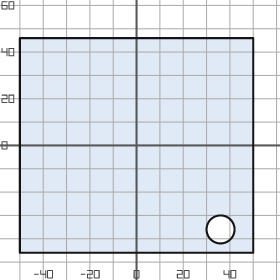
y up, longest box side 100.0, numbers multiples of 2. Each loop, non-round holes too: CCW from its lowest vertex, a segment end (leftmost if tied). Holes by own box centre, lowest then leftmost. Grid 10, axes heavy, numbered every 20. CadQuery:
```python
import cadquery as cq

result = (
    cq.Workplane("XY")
    .moveTo(-50.0, -46.0)
    .lineTo(50.0, -46.0)
    .lineTo(50.0, 46.0)
    .lineTo(-50.0, 46.0)
    .close()
    .moveTo(36.0, -36.0)
    .circle(6.0)
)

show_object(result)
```